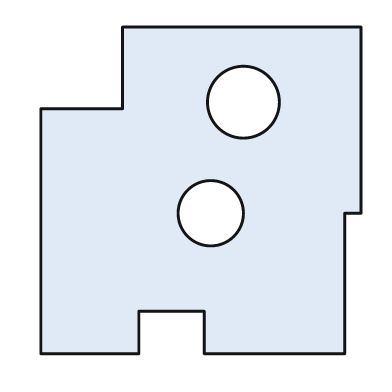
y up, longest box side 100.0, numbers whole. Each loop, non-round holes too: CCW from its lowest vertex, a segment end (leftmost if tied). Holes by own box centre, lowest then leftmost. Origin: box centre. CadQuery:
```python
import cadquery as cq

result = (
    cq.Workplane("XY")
    .moveTo(-49.0, -50.0)
    .lineTo(-19.0, -50.0)
    .lineTo(-19.0, -37.0)
    .lineTo(1.0, -37.0)
    .lineTo(1.0, -50.0)
    .lineTo(44.0, -50.0)
    .lineTo(44.0, -7.0)
    .lineTo(49.0, -7.0)
    .lineTo(49.0, 50.0)
    .lineTo(-24.0, 50.0)
    .lineTo(-24.0, 25.0)
    .lineTo(-49.0, 25.0)
    .close()
    .moveTo(3.0, -7.0)
    .circle(10.0)
    .moveTo(13.0, 27.0)
    .circle(11.0)
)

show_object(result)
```